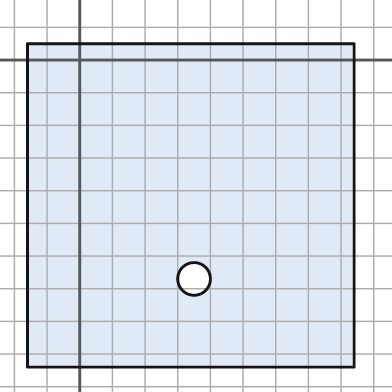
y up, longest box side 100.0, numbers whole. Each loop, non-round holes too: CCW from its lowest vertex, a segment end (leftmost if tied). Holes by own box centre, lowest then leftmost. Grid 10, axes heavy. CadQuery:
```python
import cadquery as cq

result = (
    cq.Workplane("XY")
    .moveTo(-16.0, -94.0)
    .lineTo(84.0, -94.0)
    .lineTo(84.0, 5.0)
    .lineTo(-16.0, 5.0)
    .close()
    .moveTo(35.0, -67.0)
    .circle(5.0)
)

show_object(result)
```